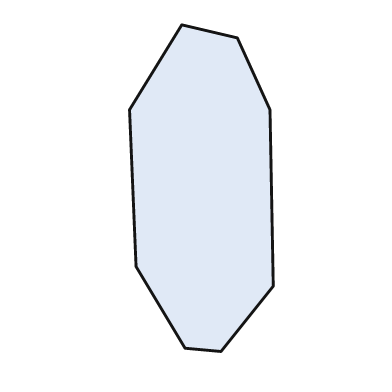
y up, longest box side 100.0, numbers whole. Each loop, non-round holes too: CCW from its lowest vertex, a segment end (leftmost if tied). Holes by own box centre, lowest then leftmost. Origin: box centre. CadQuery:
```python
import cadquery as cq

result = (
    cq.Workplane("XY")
    .moveTo(6.0, -50.0)
    .lineTo(22.0, -30.0)
    .lineTo(21.0, 24.0)
    .lineTo(11.0, 46.0)
    .lineTo(-6.0, 50.0)
    .lineTo(-22.0, 24.0)
    .lineTo(-20.0, -24.0)
    .lineTo(-5.0, -49.0)
    .close()
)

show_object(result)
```